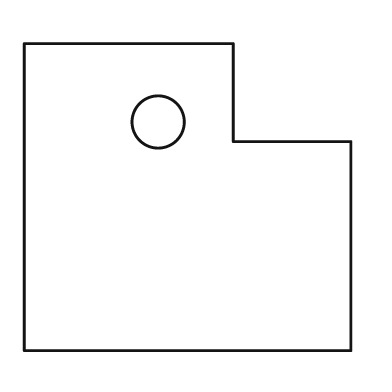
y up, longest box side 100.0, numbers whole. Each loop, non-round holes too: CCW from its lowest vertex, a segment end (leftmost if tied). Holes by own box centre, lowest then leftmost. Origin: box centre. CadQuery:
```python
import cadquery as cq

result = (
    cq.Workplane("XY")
    .moveTo(-50.0, -47.0)
    .lineTo(50.0, -47.0)
    .lineTo(50.0, 17.0)
    .lineTo(14.0, 17.0)
    .lineTo(14.0, 47.0)
    .lineTo(-50.0, 47.0)
    .close()
    .moveTo(-9.0, 23.0)
    .circle(8.0)
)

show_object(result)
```